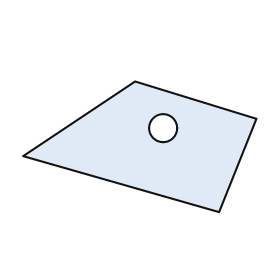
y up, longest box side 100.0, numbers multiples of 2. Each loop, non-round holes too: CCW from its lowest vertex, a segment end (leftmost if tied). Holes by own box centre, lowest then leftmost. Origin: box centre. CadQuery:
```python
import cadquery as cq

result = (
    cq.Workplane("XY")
    .moveTo(34.0, -28.0)
    .lineTo(50.0, 12.0)
    .lineTo(-2.0, 28.0)
    .lineTo(-50.0, -4.0)
    .close()
    .moveTo(10.0, 8.0)
    .circle(6.0)
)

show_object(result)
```